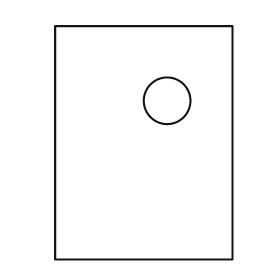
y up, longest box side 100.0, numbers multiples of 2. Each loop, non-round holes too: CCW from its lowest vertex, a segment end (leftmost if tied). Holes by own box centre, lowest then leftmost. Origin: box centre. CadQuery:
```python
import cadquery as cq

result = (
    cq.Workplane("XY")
    .moveTo(-38.0, -50.0)
    .lineTo(38.0, -50.0)
    .lineTo(38.0, 50.0)
    .lineTo(-38.0, 50.0)
    .close()
    .moveTo(10.0, 18.0)
    .circle(10.0)
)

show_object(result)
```